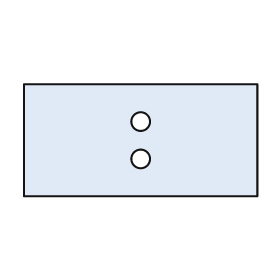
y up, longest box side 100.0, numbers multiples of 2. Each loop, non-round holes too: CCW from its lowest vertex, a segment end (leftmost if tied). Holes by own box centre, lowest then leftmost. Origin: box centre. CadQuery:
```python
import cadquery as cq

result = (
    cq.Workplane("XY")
    .moveTo(-50.0, -24.0)
    .lineTo(50.0, -24.0)
    .lineTo(50.0, 24.0)
    .lineTo(-50.0, 24.0)
    .close()
    .moveTo(0.0, -8.0)
    .circle(4.0)
    .moveTo(0.0, 8.0)
    .circle(4.0)
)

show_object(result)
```